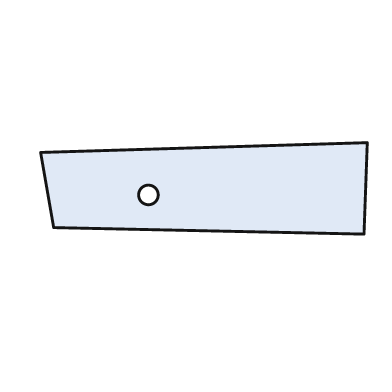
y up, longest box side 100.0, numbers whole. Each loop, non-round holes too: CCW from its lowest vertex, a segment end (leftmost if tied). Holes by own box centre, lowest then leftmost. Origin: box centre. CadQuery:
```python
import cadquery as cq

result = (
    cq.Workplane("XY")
    .moveTo(49.0, -14.0)
    .lineTo(50.0, 14.0)
    .lineTo(-50.0, 11.0)
    .lineTo(-46.0, -12.0)
    .close()
    .moveTo(-17.0, -2.0)
    .circle(3.0)
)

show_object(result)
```